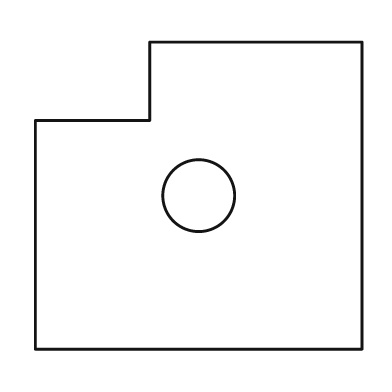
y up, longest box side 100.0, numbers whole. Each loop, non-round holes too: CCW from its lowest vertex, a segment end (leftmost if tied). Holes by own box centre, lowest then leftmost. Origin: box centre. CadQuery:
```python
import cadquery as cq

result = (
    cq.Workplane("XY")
    .moveTo(-50.0, -47.0)
    .lineTo(50.0, -47.0)
    .lineTo(50.0, 47.0)
    .lineTo(-15.0, 47.0)
    .lineTo(-15.0, 23.0)
    .lineTo(-50.0, 23.0)
    .close()
    .moveTo(0.0, 0.0)
    .circle(11.0)
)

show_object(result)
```